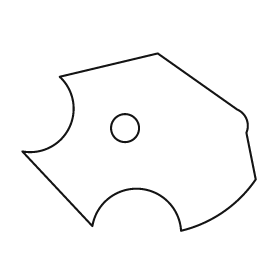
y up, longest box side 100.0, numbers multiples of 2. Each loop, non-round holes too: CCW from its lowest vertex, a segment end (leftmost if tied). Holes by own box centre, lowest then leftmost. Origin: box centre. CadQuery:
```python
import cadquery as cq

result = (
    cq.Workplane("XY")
    .moveTo(18.0, -38.0)
    .threePointArc((36.0, -30.0), (50.0, -16.0))
    .lineTo(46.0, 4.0)
    .threePointArc((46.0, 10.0), (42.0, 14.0))
    .lineTo(8.0, 38.0)
    .lineTo(-34.0, 28.0)
    .threePointArc((-30.0, 6.0), (-50.0, -4.0))
    .lineTo(-20.0, -36.0)
    .threePointArc((0.0, -20.0), (18.0, -38.0))
    .close()
    .moveTo(-6.0, 6.0)
    .circle(6.0)
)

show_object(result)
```